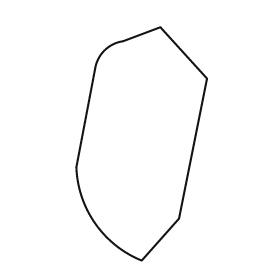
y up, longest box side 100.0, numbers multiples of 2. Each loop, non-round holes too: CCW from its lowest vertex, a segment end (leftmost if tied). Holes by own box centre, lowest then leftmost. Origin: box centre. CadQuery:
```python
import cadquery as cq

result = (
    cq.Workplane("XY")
    .moveTo(0.0, -50.0)
    .lineTo(16.0, -32.0)
    .lineTo(28.0, 28.0)
    .lineTo(8.0, 50.0)
    .lineTo(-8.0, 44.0)
    .threePointArc((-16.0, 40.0), (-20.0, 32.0))
    .lineTo(-28.0, -10.0)
    .threePointArc((-20.0, -34.0), (0.0, -50.0))
    .close()
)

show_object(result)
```